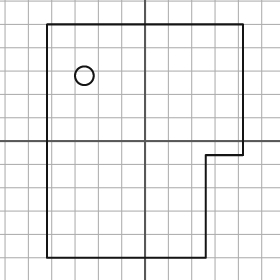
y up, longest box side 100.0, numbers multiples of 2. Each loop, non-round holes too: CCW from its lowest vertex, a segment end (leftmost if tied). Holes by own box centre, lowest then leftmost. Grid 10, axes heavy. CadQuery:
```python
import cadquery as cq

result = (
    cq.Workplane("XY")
    .moveTo(-42.0, -50.0)
    .lineTo(26.0, -50.0)
    .lineTo(26.0, -6.0)
    .lineTo(42.0, -6.0)
    .lineTo(42.0, 50.0)
    .lineTo(-42.0, 50.0)
    .close()
    .moveTo(-26.0, 28.0)
    .circle(4.0)
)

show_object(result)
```